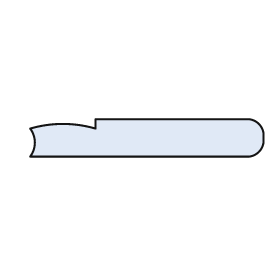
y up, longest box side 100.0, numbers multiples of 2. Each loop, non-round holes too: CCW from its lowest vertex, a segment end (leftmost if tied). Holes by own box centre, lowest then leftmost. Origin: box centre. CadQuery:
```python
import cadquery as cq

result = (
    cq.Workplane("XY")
    .moveTo(-50.0, -8.0)
    .lineTo(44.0, -8.0)
    .threePointArc((48.0, -6.0), (50.0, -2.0))
    .lineTo(50.0, 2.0)
    .threePointArc((48.0, 6.0), (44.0, 8.0))
    .lineTo(-22.0, 8.0)
    .lineTo(-22.0, 4.0)
    .threePointArc((-36.0, 6.0), (-50.0, 4.0))
    .threePointArc((-48.0, -2.0), (-50.0, -8.0))
    .close()
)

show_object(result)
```